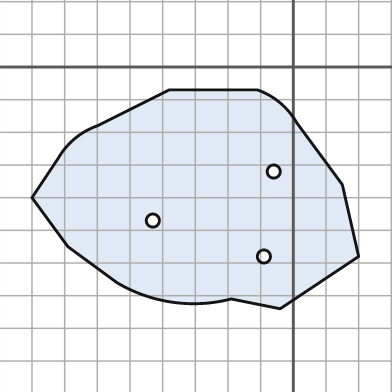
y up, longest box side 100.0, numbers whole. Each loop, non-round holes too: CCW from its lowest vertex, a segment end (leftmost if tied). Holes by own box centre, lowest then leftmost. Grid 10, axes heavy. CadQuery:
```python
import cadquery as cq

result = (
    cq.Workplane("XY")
    .moveTo(-4.0, -74.0)
    .lineTo(20.0, -58.0)
    .lineTo(15.0, -36.0)
    .lineTo(1.0, -17.0)
    .threePointArc((-4.0, -11.0), (-11.0, -7.0))
    .lineTo(-38.0, -7.0)
    .lineTo(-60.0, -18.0)
    .threePointArc((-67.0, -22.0), (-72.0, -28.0))
    .lineTo(-80.0, -40.0)
    .lineTo(-69.0, -55.0)
    .lineTo(-54.0, -66.0)
    .threePointArc((-37.0, -72.0), (-19.0, -71.0))
    .close()
    .moveTo(-9.0, -58.0)
    .circle(2.0)
    .moveTo(-43.0, -47.0)
    .circle(2.0)
    .moveTo(-6.0, -32.0)
    .circle(2.0)
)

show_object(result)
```